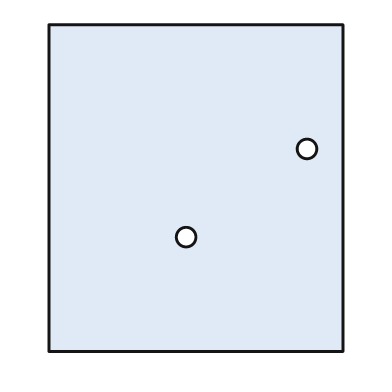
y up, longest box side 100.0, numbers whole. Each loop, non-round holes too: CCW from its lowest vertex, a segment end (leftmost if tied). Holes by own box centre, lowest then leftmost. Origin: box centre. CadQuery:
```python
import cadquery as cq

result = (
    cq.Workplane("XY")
    .moveTo(-45.0, -50.0)
    .lineTo(45.0, -50.0)
    .lineTo(45.0, 50.0)
    .lineTo(-45.0, 50.0)
    .close()
    .moveTo(-3.0, -15.0)
    .circle(3.0)
    .moveTo(34.0, 12.0)
    .circle(3.0)
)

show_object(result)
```